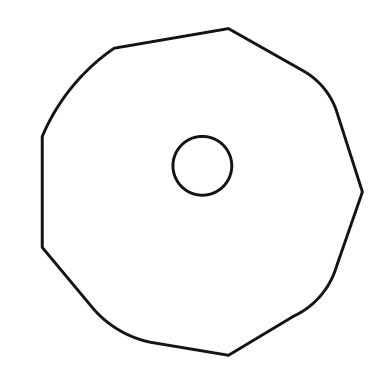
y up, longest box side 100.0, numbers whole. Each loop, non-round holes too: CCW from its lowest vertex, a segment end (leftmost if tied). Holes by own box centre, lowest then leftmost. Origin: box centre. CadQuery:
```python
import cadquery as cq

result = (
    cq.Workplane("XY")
    .moveTo(8.0, -50.0)
    .lineTo(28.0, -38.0)
    .threePointArc((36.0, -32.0), (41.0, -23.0))
    .lineTo(49.0, 0.0)
    .lineTo(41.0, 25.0)
    .threePointArc((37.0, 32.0), (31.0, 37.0))
    .lineTo(8.0, 50.0)
    .lineTo(-27.0, 44.0)
    .threePointArc((-40.0, 32.0), (-49.0, 17.0))
    .lineTo(-49.0, -17.0)
    .lineTo(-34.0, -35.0)
    .threePointArc((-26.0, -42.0), (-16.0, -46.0))
    .close()
    .moveTo(0.0, 8.0)
    .circle(9.0)
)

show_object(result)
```